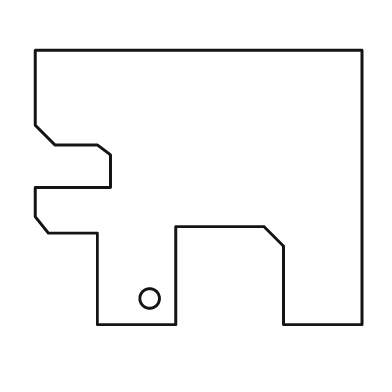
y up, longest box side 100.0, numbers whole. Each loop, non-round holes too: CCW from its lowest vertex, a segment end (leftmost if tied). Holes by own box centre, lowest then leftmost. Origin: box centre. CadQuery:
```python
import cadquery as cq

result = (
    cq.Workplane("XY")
    .moveTo(-31.0, -42.0)
    .lineTo(-7.0, -42.0)
    .lineTo(-7.0, -12.0)
    .lineTo(20.0, -12.0)
    .lineTo(26.0, -18.0)
    .lineTo(26.0, -42.0)
    .lineTo(50.0, -42.0)
    .lineTo(50.0, 42.0)
    .lineTo(-50.0, 42.0)
    .lineTo(-50.0, 19.0)
    .lineTo(-44.0, 13.0)
    .lineTo(-31.0, 13.0)
    .lineTo(-27.0, 10.0)
    .lineTo(-27.0, 0.0)
    .lineTo(-50.0, 0.0)
    .lineTo(-50.0, -9.0)
    .lineTo(-46.0, -14.0)
    .lineTo(-31.0, -14.0)
    .close()
    .moveTo(-15.0, -34.0)
    .circle(3.0)
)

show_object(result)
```